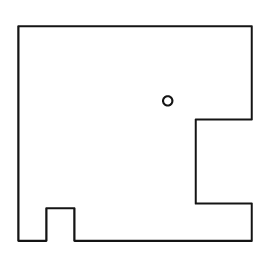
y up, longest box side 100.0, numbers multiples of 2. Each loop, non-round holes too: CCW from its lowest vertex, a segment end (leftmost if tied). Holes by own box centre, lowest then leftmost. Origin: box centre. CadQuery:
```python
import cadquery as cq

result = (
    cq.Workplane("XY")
    .moveTo(-50.0, -46.0)
    .lineTo(-38.0, -46.0)
    .lineTo(-38.0, -32.0)
    .lineTo(-26.0, -32.0)
    .lineTo(-26.0, -46.0)
    .lineTo(50.0, -46.0)
    .lineTo(50.0, -30.0)
    .lineTo(26.0, -30.0)
    .lineTo(26.0, 6.0)
    .lineTo(50.0, 6.0)
    .lineTo(50.0, 46.0)
    .lineTo(-50.0, 46.0)
    .close()
    .moveTo(14.0, 14.0)
    .circle(2.0)
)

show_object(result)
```